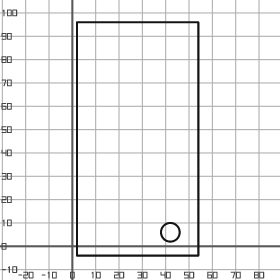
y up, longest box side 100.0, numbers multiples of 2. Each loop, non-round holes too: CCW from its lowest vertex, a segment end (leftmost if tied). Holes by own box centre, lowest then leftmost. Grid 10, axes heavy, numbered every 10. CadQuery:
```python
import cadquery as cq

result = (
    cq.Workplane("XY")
    .moveTo(2.0, -4.0)
    .lineTo(54.0, -4.0)
    .lineTo(54.0, 96.0)
    .lineTo(2.0, 96.0)
    .close()
    .moveTo(42.0, 6.0)
    .circle(4.0)
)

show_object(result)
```